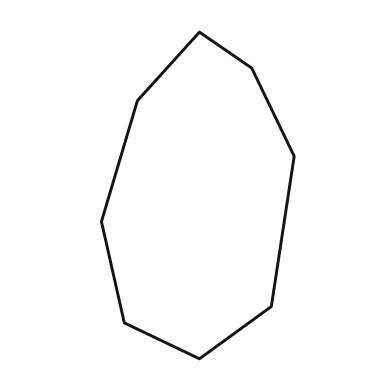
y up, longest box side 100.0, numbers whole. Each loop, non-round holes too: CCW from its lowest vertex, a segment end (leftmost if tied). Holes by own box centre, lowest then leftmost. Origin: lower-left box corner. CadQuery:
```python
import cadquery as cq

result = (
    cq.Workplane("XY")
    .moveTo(30.0, 0.0)
    .lineTo(52.0, 16.0)
    .lineTo(59.0, 62.0)
    .lineTo(46.0, 89.0)
    .lineTo(30.0, 100.0)
    .lineTo(11.0, 79.0)
    .lineTo(0.0, 42.0)
    .lineTo(7.0, 11.0)
    .close()
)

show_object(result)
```